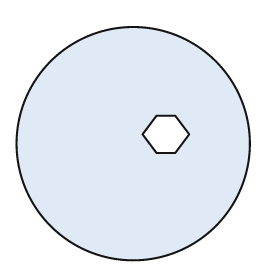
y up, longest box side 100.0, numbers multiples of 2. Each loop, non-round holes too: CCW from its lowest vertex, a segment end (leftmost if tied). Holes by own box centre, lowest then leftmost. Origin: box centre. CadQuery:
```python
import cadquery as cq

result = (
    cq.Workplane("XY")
    .moveTo(0.0, 0.0)
    .circle(50.0)
    .moveTo(10.0, -4.0)
    .lineTo(18.0, -4.0)
    .lineTo(24.0, 4.0)
    .lineTo(18.0, 12.0)
    .lineTo(10.0, 12.0)
    .lineTo(4.0, 4.0)
    .close()
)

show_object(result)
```